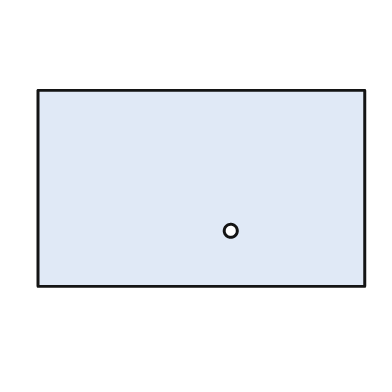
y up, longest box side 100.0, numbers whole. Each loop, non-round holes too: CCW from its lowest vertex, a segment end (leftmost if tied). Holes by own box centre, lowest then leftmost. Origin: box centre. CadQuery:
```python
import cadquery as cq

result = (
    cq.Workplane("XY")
    .moveTo(-50.0, -30.0)
    .lineTo(50.0, -30.0)
    .lineTo(50.0, 30.0)
    .lineTo(-50.0, 30.0)
    .close()
    .moveTo(9.0, -13.0)
    .circle(2.0)
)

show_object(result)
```